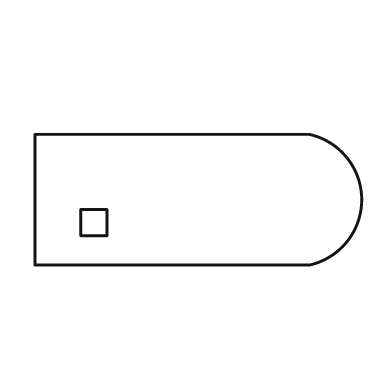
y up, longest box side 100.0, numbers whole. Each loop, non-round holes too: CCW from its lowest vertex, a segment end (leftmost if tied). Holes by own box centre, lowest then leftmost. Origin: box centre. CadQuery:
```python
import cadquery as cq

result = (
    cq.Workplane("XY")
    .moveTo(-50.0, -20.0)
    .lineTo(34.0, -20.0)
    .threePointArc((50.0, 0.0), (34.0, 20.0))
    .lineTo(-50.0, 20.0)
    .close()
    .moveTo(-36.0, -11.0)
    .lineTo(-28.0, -11.0)
    .lineTo(-28.0, -3.0)
    .lineTo(-36.0, -3.0)
    .close()
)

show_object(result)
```